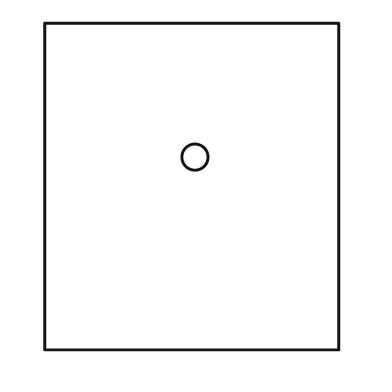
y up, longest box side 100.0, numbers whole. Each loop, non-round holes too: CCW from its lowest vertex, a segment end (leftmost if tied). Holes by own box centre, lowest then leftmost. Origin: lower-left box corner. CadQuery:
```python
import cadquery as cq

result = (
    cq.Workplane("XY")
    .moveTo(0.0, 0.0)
    .lineTo(90.0, 0.0)
    .lineTo(90.0, 100.0)
    .lineTo(0.0, 100.0)
    .close()
    .moveTo(46.0, 59.0)
    .circle(4.0)
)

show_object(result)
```